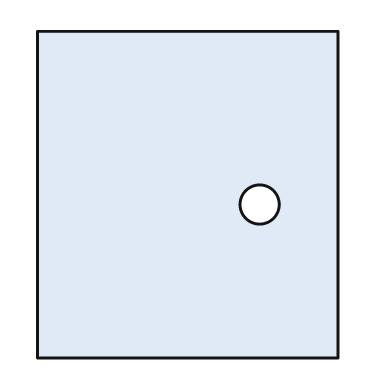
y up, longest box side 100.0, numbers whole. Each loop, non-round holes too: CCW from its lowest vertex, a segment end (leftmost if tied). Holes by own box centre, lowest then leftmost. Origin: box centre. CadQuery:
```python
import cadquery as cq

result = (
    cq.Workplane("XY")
    .moveTo(-46.0, -50.0)
    .lineTo(46.0, -50.0)
    .lineTo(46.0, 50.0)
    .lineTo(-46.0, 50.0)
    .close()
    .moveTo(22.0, -3.0)
    .circle(6.0)
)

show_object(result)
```